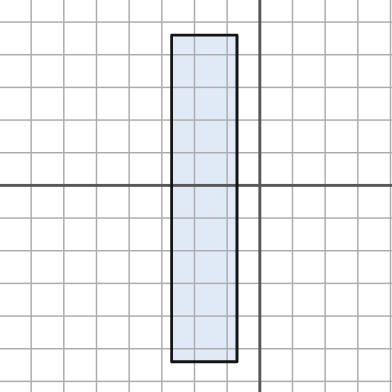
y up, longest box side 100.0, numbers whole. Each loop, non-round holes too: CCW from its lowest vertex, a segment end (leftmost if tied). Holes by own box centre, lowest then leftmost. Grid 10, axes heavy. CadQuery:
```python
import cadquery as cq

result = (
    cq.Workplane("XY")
    .moveTo(-27.0, -54.0)
    .lineTo(-7.0, -54.0)
    .lineTo(-7.0, 46.0)
    .lineTo(-27.0, 46.0)
    .close()
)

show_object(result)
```